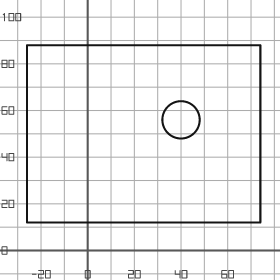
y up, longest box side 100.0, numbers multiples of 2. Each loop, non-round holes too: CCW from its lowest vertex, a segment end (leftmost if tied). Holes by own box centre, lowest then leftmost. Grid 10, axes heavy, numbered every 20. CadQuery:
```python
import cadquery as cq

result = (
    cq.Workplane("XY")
    .moveTo(-26.0, 12.0)
    .lineTo(74.0, 12.0)
    .lineTo(74.0, 88.0)
    .lineTo(-26.0, 88.0)
    .close()
    .moveTo(40.0, 56.0)
    .circle(8.0)
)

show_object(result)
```